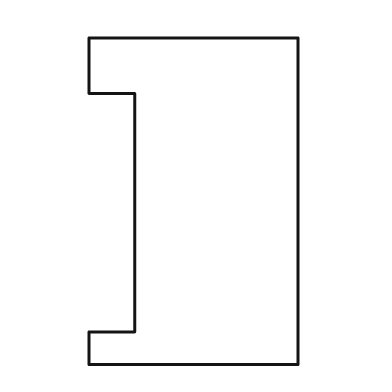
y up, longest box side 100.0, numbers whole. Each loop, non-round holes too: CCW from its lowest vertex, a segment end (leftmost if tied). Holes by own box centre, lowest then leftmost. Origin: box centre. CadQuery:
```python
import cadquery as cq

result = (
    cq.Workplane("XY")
    .moveTo(-32.0, -50.0)
    .lineTo(32.0, -50.0)
    .lineTo(32.0, 50.0)
    .lineTo(-32.0, 50.0)
    .lineTo(-32.0, 33.0)
    .lineTo(-18.0, 33.0)
    .lineTo(-18.0, -40.0)
    .lineTo(-32.0, -40.0)
    .close()
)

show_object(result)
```